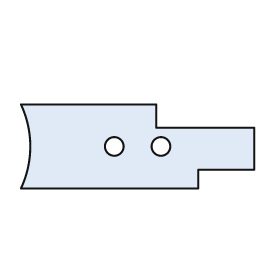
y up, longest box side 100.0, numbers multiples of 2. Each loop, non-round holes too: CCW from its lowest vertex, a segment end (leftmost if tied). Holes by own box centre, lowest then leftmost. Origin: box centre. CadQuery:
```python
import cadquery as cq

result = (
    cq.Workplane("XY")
    .moveTo(-50.0, -18.0)
    .lineTo(26.0, -18.0)
    .lineTo(26.0, -10.0)
    .lineTo(50.0, -10.0)
    .lineTo(50.0, 8.0)
    .lineTo(8.0, 8.0)
    .lineTo(8.0, 18.0)
    .lineTo(-50.0, 18.0)
    .threePointArc((-46.0, 0.0), (-50.0, -18.0))
    .close()
    .moveTo(-10.0, 0.0)
    .circle(4.0)
    .moveTo(10.0, 0.0)
    .circle(4.0)
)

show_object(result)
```